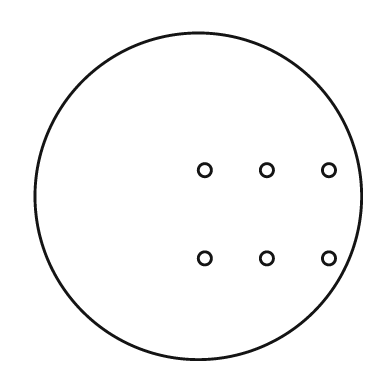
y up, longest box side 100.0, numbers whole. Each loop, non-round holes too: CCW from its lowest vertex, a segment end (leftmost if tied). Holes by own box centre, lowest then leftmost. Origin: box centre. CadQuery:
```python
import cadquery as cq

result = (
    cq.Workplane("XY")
    .moveTo(0.0, 0.0)
    .circle(50.0)
    .moveTo(2.0, -19.0)
    .circle(2.0)
    .moveTo(21.0, -19.0)
    .circle(2.0)
    .moveTo(40.0, -19.0)
    .circle(2.0)
    .moveTo(2.0, 8.0)
    .circle(2.0)
    .moveTo(21.0, 8.0)
    .circle(2.0)
    .moveTo(40.0, 8.0)
    .circle(2.0)
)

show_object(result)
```